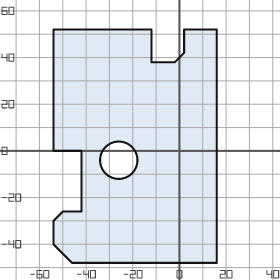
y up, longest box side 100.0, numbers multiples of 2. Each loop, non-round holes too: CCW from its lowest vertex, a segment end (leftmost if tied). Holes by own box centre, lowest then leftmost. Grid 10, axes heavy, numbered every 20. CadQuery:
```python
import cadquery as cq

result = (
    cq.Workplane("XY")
    .moveTo(-46.0, -48.0)
    .lineTo(16.0, -48.0)
    .lineTo(16.0, 52.0)
    .lineTo(2.0, 52.0)
    .lineTo(2.0, 42.0)
    .lineTo(-2.0, 38.0)
    .lineTo(-12.0, 38.0)
    .lineTo(-12.0, 52.0)
    .lineTo(-54.0, 52.0)
    .lineTo(-54.0, 0.0)
    .lineTo(-42.0, 0.0)
    .lineTo(-42.0, -26.0)
    .lineTo(-50.0, -26.0)
    .lineTo(-54.0, -30.0)
    .lineTo(-54.0, -40.0)
    .close()
    .moveTo(-26.0, -4.0)
    .circle(8.0)
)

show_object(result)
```